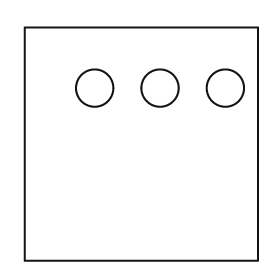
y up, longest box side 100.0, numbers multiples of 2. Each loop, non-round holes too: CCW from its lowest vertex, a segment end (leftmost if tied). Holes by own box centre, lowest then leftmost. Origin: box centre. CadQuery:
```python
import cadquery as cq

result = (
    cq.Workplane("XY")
    .moveTo(-50.0, -50.0)
    .lineTo(50.0, -50.0)
    .lineTo(50.0, 50.0)
    .lineTo(-50.0, 50.0)
    .close()
    .moveTo(-20.0, 24.0)
    .circle(8.0)
    .moveTo(8.0, 24.0)
    .circle(8.0)
    .moveTo(36.0, 24.0)
    .circle(8.0)
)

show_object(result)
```